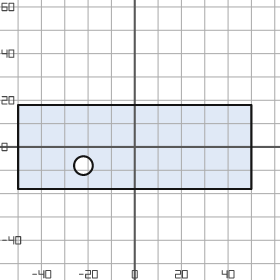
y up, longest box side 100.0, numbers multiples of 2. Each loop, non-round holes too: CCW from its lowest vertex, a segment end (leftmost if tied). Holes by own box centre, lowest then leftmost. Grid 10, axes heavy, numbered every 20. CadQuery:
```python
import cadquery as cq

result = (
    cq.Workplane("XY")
    .moveTo(-50.0, -18.0)
    .lineTo(50.0, -18.0)
    .lineTo(50.0, 18.0)
    .lineTo(-50.0, 18.0)
    .close()
    .moveTo(-22.0, -8.0)
    .circle(4.0)
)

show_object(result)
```